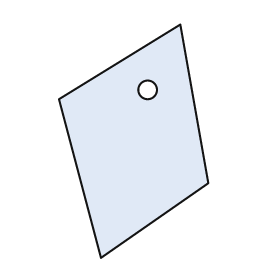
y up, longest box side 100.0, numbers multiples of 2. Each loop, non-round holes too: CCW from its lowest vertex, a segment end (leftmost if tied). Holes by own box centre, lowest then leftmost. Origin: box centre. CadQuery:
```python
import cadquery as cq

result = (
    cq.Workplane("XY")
    .moveTo(-14.0, -50.0)
    .lineTo(32.0, -18.0)
    .lineTo(20.0, 50.0)
    .lineTo(-32.0, 18.0)
    .close()
    .moveTo(6.0, 22.0)
    .circle(4.0)
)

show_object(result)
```